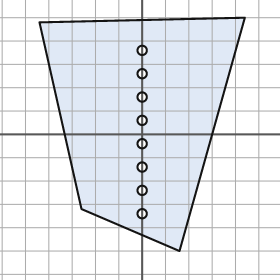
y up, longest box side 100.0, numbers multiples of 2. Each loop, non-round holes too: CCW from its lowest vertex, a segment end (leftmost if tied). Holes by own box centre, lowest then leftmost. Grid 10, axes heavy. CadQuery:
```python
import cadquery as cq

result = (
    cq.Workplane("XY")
    .moveTo(16.0, -50.0)
    .lineTo(44.0, 50.0)
    .lineTo(-44.0, 48.0)
    .lineTo(-26.0, -32.0)
    .close()
    .moveTo(0.0, -34.0)
    .circle(2.0)
    .moveTo(0.0, -24.0)
    .circle(2.0)
    .moveTo(0.0, -14.0)
    .circle(2.0)
    .moveTo(0.0, -4.0)
    .circle(2.0)
    .moveTo(0.0, 6.0)
    .circle(2.0)
    .moveTo(0.0, 16.0)
    .circle(2.0)
    .moveTo(0.0, 26.0)
    .circle(2.0)
    .moveTo(0.0, 36.0)
    .circle(2.0)
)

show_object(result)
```